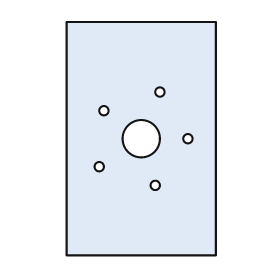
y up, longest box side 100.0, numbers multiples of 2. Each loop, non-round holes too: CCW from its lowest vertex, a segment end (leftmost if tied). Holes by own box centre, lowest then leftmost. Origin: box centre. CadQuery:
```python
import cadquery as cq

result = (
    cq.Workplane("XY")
    .moveTo(-32.0, -50.0)
    .lineTo(32.0, -50.0)
    .lineTo(32.0, 50.0)
    .lineTo(-32.0, 50.0)
    .close()
    .moveTo(6.0, -20.0)
    .circle(2.0)
    .moveTo(-18.0, -12.0)
    .circle(2.0)
    .moveTo(0.0, 0.0)
    .circle(8.0)
    .moveTo(20.0, 0.0)
    .circle(2.0)
    .moveTo(-16.0, 12.0)
    .circle(2.0)
    .moveTo(8.0, 20.0)
    .circle(2.0)
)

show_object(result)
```